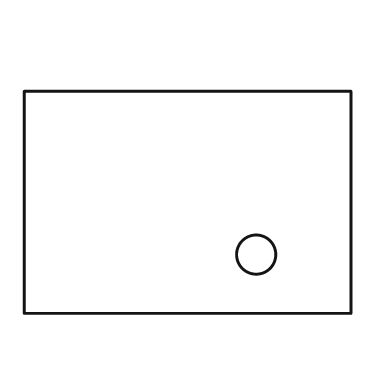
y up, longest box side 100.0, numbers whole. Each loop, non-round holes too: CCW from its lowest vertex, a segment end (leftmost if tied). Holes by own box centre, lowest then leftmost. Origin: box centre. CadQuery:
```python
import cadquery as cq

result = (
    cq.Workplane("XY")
    .moveTo(-50.0, -34.0)
    .lineTo(50.0, -34.0)
    .lineTo(50.0, 34.0)
    .lineTo(-50.0, 34.0)
    .close()
    .moveTo(21.0, -16.0)
    .circle(6.0)
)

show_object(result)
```